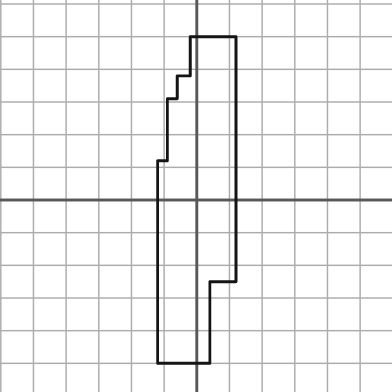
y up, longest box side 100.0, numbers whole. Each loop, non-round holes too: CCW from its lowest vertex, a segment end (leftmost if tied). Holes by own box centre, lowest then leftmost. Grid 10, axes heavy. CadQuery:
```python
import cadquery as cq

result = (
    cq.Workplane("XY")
    .moveTo(-12.0, -50.0)
    .lineTo(4.0, -50.0)
    .lineTo(4.0, -25.0)
    .lineTo(12.0, -25.0)
    .lineTo(12.0, 50.0)
    .lineTo(-2.0, 50.0)
    .lineTo(-2.0, 38.0)
    .lineTo(-6.0, 38.0)
    .lineTo(-6.0, 31.0)
    .lineTo(-9.0, 31.0)
    .lineTo(-9.0, 12.0)
    .lineTo(-12.0, 12.0)
    .close()
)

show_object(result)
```